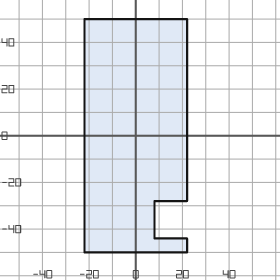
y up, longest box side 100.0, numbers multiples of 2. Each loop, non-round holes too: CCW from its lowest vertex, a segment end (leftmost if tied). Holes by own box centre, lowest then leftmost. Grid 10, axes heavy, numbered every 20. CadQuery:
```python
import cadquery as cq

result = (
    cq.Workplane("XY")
    .moveTo(-22.0, -50.0)
    .lineTo(22.0, -50.0)
    .lineTo(22.0, -44.0)
    .lineTo(8.0, -44.0)
    .lineTo(8.0, -28.0)
    .lineTo(22.0, -28.0)
    .lineTo(22.0, 50.0)
    .lineTo(-22.0, 50.0)
    .close()
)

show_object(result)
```